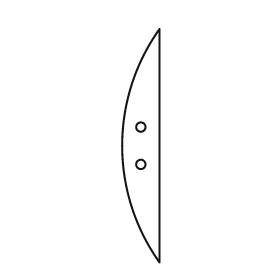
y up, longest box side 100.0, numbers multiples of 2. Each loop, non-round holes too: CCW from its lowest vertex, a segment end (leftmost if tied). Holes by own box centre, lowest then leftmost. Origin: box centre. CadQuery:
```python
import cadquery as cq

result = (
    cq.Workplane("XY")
    .moveTo(8.0, -50.0)
    .lineTo(8.0, 50.0)
    .threePointArc((-8.0, 0.0), (8.0, -50.0))
    .close()
    .moveTo(0.0, -8.0)
    .circle(2.0)
    .moveTo(0.0, 8.0)
    .circle(2.0)
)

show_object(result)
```